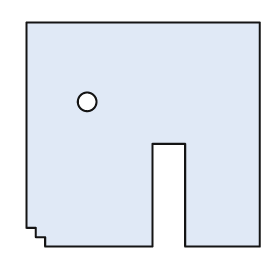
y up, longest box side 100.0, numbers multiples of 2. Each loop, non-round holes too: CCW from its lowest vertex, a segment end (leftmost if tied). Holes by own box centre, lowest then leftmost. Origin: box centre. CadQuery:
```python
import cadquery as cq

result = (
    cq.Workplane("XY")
    .moveTo(-42.0, -48.0)
    .lineTo(4.0, -48.0)
    .lineTo(4.0, -4.0)
    .lineTo(18.0, -4.0)
    .lineTo(18.0, -48.0)
    .lineTo(50.0, -48.0)
    .lineTo(50.0, 48.0)
    .lineTo(-50.0, 48.0)
    .lineTo(-50.0, -40.0)
    .lineTo(-46.0, -40.0)
    .lineTo(-46.0, -44.0)
    .lineTo(-42.0, -44.0)
    .close()
    .moveTo(-24.0, 14.0)
    .circle(4.0)
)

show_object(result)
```